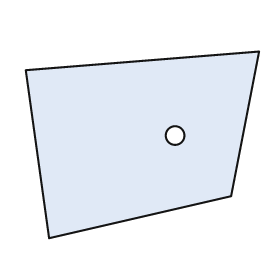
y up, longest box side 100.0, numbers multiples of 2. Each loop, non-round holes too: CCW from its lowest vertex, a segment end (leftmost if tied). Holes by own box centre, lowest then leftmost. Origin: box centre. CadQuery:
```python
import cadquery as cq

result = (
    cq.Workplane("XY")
    .moveTo(-40.0, -40.0)
    .lineTo(38.0, -22.0)
    .lineTo(50.0, 40.0)
    .lineTo(-50.0, 32.0)
    .close()
    .moveTo(14.0, 4.0)
    .circle(4.0)
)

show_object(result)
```